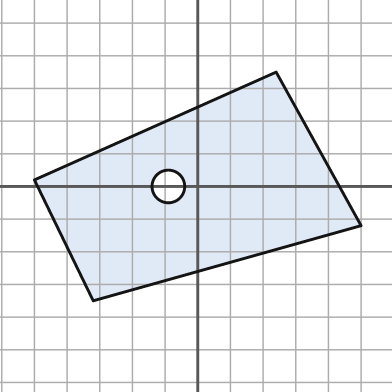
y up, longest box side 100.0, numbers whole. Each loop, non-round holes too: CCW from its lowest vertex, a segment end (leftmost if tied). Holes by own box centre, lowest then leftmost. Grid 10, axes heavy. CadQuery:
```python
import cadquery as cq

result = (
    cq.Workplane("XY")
    .moveTo(-32.0, -35.0)
    .lineTo(50.0, -12.0)
    .lineTo(24.0, 35.0)
    .lineTo(-50.0, 2.0)
    .close()
    .moveTo(-9.0, 0.0)
    .circle(5.0)
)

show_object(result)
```